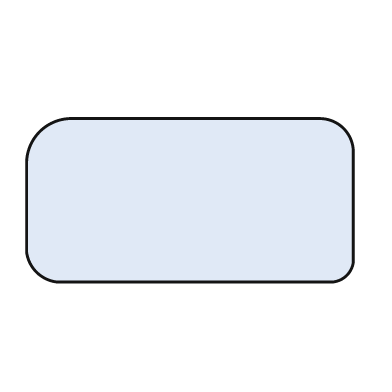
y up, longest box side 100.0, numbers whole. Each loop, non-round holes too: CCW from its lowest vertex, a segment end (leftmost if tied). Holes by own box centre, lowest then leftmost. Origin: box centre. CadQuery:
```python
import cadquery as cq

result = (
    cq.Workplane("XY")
    .moveTo(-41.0, -25.0)
    .lineTo(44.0, -25.0)
    .threePointArc((48.0, -23.0), (50.0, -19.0))
    .lineTo(50.0, 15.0)
    .threePointArc((47.0, 22.0), (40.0, 25.0))
    .lineTo(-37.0, 25.0)
    .threePointArc((-46.0, 21.0), (-50.0, 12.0))
    .lineTo(-50.0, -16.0)
    .threePointArc((-47.0, -22.0), (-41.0, -25.0))
    .close()
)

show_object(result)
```